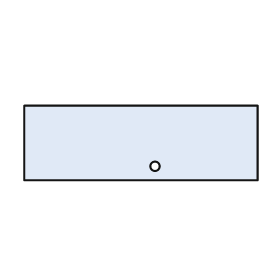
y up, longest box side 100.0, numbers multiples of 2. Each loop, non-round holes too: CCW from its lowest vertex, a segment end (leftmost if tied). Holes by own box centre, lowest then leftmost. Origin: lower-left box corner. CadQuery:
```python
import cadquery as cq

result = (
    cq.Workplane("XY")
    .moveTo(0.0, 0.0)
    .lineTo(100.0, 0.0)
    .lineTo(100.0, 32.0)
    .lineTo(0.0, 32.0)
    .close()
    .moveTo(56.0, 6.0)
    .circle(2.0)
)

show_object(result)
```